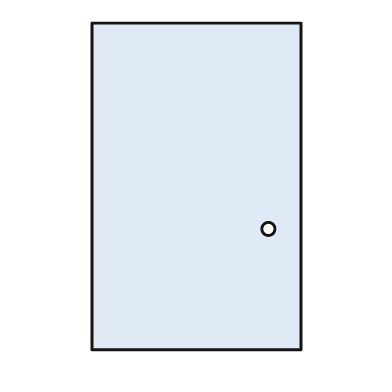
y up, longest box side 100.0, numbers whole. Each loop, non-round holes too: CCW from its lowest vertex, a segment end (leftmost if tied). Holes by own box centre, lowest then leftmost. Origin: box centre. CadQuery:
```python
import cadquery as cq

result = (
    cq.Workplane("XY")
    .moveTo(-32.0, -50.0)
    .lineTo(32.0, -50.0)
    .lineTo(32.0, 50.0)
    .lineTo(-32.0, 50.0)
    .close()
    .moveTo(22.0, -13.0)
    .circle(2.0)
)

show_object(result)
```